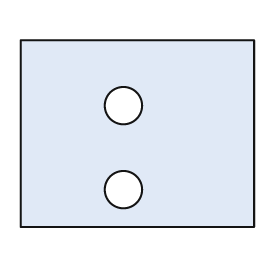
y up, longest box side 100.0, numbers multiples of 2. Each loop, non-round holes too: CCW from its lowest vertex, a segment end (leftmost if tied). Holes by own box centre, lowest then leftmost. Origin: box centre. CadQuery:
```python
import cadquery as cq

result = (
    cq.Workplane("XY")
    .moveTo(-50.0, -40.0)
    .lineTo(50.0, -40.0)
    .lineTo(50.0, 40.0)
    .lineTo(-50.0, 40.0)
    .close()
    .moveTo(-6.0, -24.0)
    .circle(8.0)
    .moveTo(-6.0, 12.0)
    .circle(8.0)
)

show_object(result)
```